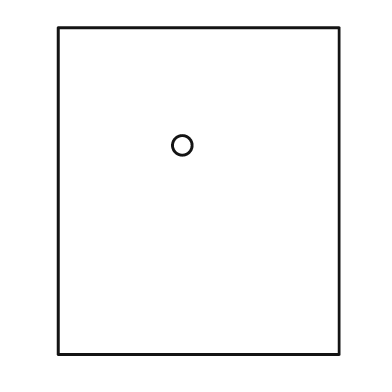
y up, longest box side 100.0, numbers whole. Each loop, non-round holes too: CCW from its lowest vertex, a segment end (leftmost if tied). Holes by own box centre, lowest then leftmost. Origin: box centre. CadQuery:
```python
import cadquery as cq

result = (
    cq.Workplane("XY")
    .moveTo(-43.0, -50.0)
    .lineTo(43.0, -50.0)
    .lineTo(43.0, 50.0)
    .lineTo(-43.0, 50.0)
    .close()
    .moveTo(-5.0, 14.0)
    .circle(3.0)
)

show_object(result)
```